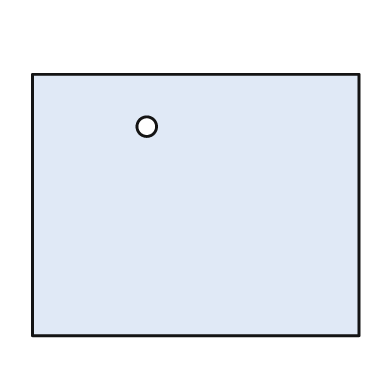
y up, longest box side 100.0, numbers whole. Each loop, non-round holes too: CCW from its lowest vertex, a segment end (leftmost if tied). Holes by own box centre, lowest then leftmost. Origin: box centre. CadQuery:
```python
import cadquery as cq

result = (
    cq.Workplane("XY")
    .moveTo(-50.0, -40.0)
    .lineTo(50.0, -40.0)
    .lineTo(50.0, 40.0)
    .lineTo(-50.0, 40.0)
    .close()
    .moveTo(-15.0, 24.0)
    .circle(3.0)
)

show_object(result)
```